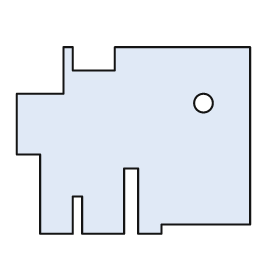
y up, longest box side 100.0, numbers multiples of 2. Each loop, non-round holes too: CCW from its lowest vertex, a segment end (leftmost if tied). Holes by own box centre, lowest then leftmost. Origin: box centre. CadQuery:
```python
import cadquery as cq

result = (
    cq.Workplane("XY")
    .moveTo(-40.0, -40.0)
    .lineTo(-26.0, -40.0)
    .lineTo(-26.0, -24.0)
    .lineTo(-22.0, -24.0)
    .lineTo(-22.0, -40.0)
    .lineTo(-4.0, -40.0)
    .lineTo(-4.0, -12.0)
    .lineTo(2.0, -12.0)
    .lineTo(2.0, -40.0)
    .lineTo(12.0, -40.0)
    .lineTo(12.0, -36.0)
    .lineTo(50.0, -36.0)
    .lineTo(50.0, 40.0)
    .lineTo(-8.0, 40.0)
    .lineTo(-8.0, 30.0)
    .lineTo(-26.0, 30.0)
    .lineTo(-26.0, 40.0)
    .lineTo(-30.0, 40.0)
    .lineTo(-30.0, 20.0)
    .lineTo(-50.0, 20.0)
    .lineTo(-50.0, -6.0)
    .lineTo(-40.0, -6.0)
    .close()
    .moveTo(30.0, 16.0)
    .circle(4.0)
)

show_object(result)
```